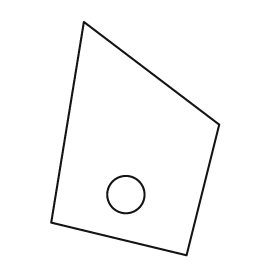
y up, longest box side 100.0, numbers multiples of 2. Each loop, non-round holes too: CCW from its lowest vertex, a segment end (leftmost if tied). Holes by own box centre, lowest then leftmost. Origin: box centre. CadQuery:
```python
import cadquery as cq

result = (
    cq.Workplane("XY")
    .moveTo(22.0, -50.0)
    .lineTo(36.0, 6.0)
    .lineTo(-22.0, 50.0)
    .lineTo(-36.0, -36.0)
    .close()
    .moveTo(-4.0, -24.0)
    .circle(8.0)
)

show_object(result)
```